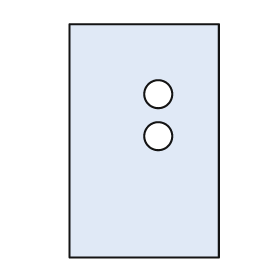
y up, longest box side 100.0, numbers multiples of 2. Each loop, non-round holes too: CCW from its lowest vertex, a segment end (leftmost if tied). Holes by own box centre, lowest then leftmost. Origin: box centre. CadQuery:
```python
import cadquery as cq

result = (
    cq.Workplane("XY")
    .moveTo(-32.0, -50.0)
    .lineTo(32.0, -50.0)
    .lineTo(32.0, 50.0)
    .lineTo(-32.0, 50.0)
    .close()
    .moveTo(6.0, 2.0)
    .circle(6.0)
    .moveTo(6.0, 20.0)
    .circle(6.0)
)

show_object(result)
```